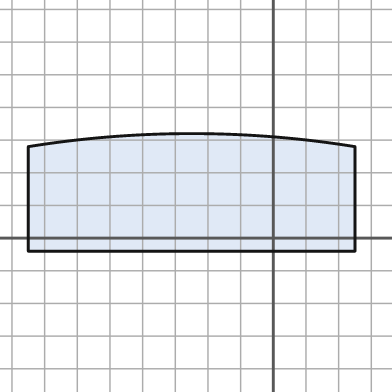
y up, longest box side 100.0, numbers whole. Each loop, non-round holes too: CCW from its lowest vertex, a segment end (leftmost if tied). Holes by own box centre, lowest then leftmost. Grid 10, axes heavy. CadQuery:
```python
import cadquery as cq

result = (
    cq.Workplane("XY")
    .moveTo(-75.0, -4.0)
    .lineTo(25.0, -4.0)
    .lineTo(25.0, 28.0)
    .threePointArc((-25.0, 32.0), (-75.0, 28.0))
    .close()
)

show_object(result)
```